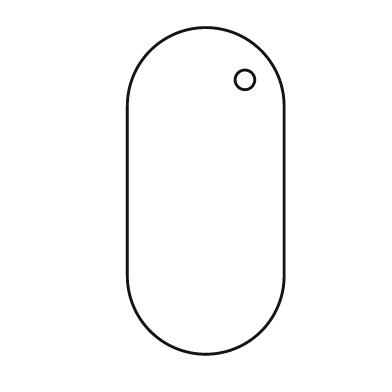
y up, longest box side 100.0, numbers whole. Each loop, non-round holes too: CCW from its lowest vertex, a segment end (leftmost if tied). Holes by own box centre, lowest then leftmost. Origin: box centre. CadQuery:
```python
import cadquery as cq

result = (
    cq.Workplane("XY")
    .moveTo(-24.0, -26.0)
    .threePointArc((0.0, -50.0), (24.0, -26.0))
    .lineTo(24.0, 26.0)
    .threePointArc((0.0, 50.0), (-24.0, 26.0))
    .close()
    .moveTo(12.0, 34.0)
    .circle(3.0)
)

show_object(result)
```